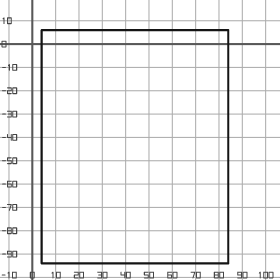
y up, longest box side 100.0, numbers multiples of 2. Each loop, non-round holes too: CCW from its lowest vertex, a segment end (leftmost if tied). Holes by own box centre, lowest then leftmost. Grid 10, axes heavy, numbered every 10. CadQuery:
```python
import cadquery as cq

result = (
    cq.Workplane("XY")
    .moveTo(4.0, -94.0)
    .lineTo(84.0, -94.0)
    .lineTo(84.0, 6.0)
    .lineTo(4.0, 6.0)
    .close()
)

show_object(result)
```